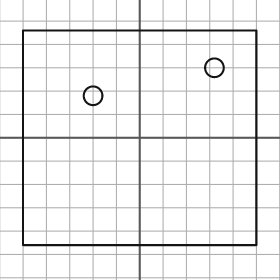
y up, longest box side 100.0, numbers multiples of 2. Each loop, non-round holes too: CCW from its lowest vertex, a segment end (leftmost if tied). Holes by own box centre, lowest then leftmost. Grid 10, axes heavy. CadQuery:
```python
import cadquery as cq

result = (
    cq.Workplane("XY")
    .moveTo(-50.0, -46.0)
    .lineTo(50.0, -46.0)
    .lineTo(50.0, 46.0)
    .lineTo(-50.0, 46.0)
    .close()
    .moveTo(-20.0, 18.0)
    .circle(4.0)
    .moveTo(32.0, 30.0)
    .circle(4.0)
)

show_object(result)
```